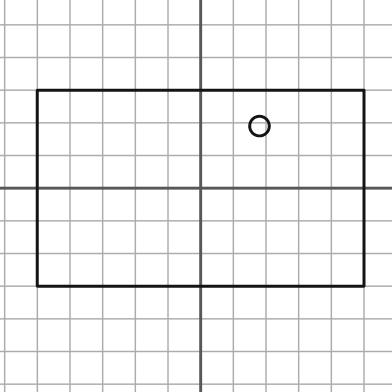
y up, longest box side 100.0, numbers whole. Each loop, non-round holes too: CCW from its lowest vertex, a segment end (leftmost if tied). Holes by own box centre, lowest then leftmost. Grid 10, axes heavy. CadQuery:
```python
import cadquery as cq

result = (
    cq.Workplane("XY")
    .moveTo(-50.0, -30.0)
    .lineTo(50.0, -30.0)
    .lineTo(50.0, 30.0)
    .lineTo(-50.0, 30.0)
    .close()
    .moveTo(18.0, 19.0)
    .circle(3.0)
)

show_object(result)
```